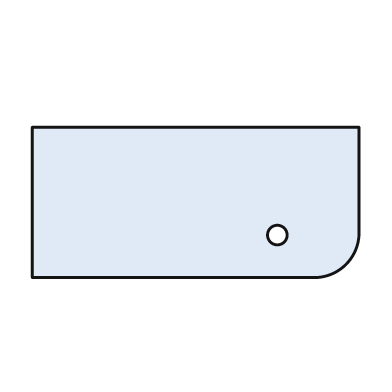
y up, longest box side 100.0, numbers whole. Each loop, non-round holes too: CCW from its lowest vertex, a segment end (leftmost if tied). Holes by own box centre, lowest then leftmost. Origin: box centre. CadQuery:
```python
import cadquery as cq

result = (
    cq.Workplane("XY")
    .moveTo(-50.0, -23.0)
    .lineTo(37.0, -23.0)
    .threePointArc((46.0, -19.0), (50.0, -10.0))
    .lineTo(50.0, 23.0)
    .lineTo(-50.0, 23.0)
    .close()
    .moveTo(25.0, -10.0)
    .circle(3.0)
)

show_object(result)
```